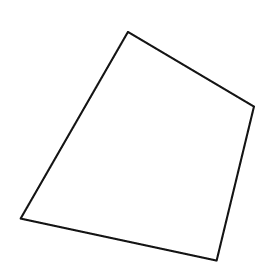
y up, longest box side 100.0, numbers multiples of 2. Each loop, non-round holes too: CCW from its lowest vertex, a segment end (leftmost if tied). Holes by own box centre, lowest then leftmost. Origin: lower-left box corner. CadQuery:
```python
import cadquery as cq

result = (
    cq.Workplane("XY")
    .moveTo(84.0, 0.0)
    .lineTo(100.0, 66.0)
    .lineTo(46.0, 98.0)
    .lineTo(0.0, 18.0)
    .close()
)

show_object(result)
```